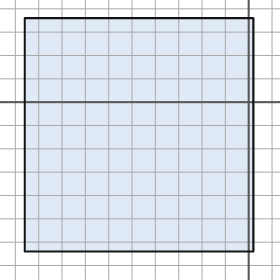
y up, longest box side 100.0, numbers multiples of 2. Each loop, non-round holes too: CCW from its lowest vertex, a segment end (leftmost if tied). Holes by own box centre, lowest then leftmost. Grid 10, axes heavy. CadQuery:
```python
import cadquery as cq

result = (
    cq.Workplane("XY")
    .moveTo(-96.0, -64.0)
    .lineTo(2.0, -64.0)
    .lineTo(2.0, 36.0)
    .lineTo(-96.0, 36.0)
    .close()
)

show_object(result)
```